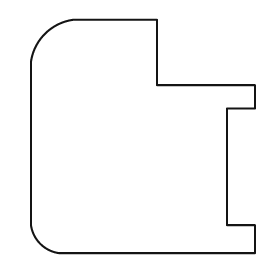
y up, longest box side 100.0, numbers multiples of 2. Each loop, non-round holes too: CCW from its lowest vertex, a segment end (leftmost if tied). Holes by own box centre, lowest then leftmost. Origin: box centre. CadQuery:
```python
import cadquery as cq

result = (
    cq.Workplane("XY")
    .moveTo(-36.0, -50.0)
    .lineTo(48.0, -50.0)
    .lineTo(48.0, -38.0)
    .lineTo(36.0, -38.0)
    .lineTo(36.0, 12.0)
    .lineTo(48.0, 12.0)
    .lineTo(48.0, 22.0)
    .lineTo(6.0, 22.0)
    .lineTo(6.0, 50.0)
    .lineTo(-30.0, 50.0)
    .threePointArc((-42.0, 44.0), (-48.0, 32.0))
    .lineTo(-48.0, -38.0)
    .threePointArc((-44.0, -46.0), (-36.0, -50.0))
    .close()
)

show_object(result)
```